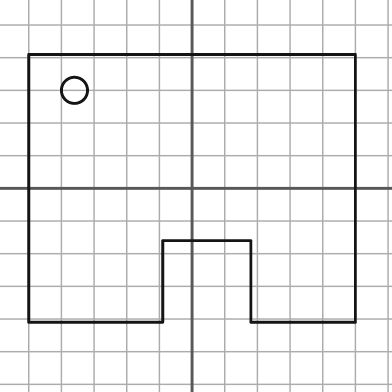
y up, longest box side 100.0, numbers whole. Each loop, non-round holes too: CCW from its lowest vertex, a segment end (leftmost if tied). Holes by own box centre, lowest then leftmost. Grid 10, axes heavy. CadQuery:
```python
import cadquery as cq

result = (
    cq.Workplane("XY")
    .moveTo(-50.0, -41.0)
    .lineTo(-9.0, -41.0)
    .lineTo(-9.0, -16.0)
    .lineTo(18.0, -16.0)
    .lineTo(18.0, -41.0)
    .lineTo(50.0, -41.0)
    .lineTo(50.0, 41.0)
    .lineTo(-50.0, 41.0)
    .close()
    .moveTo(-36.0, 30.0)
    .circle(4.0)
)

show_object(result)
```